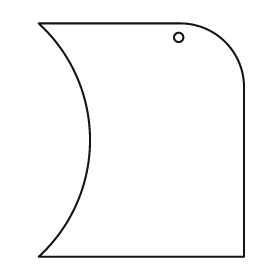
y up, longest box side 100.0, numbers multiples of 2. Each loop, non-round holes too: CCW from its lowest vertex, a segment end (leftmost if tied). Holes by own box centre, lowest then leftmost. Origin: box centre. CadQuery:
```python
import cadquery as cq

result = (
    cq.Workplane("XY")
    .moveTo(-44.0, -50.0)
    .lineTo(44.0, -50.0)
    .lineTo(44.0, 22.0)
    .threePointArc((36.0, 42.0), (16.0, 50.0))
    .lineTo(-44.0, 50.0)
    .threePointArc((-22.0, 0.0), (-44.0, -50.0))
    .close()
    .moveTo(16.0, 44.0)
    .circle(2.0)
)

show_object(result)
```